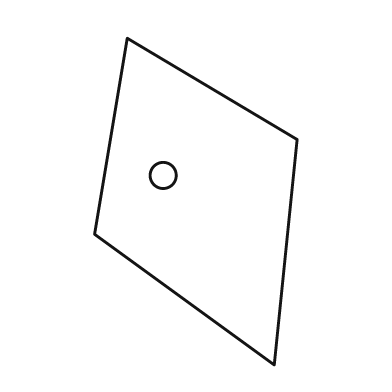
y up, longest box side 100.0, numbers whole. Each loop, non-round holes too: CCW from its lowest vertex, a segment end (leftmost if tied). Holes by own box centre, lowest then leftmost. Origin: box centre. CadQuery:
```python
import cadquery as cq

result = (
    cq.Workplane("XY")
    .moveTo(24.0, -50.0)
    .lineTo(31.0, 19.0)
    .lineTo(-21.0, 50.0)
    .lineTo(-31.0, -10.0)
    .close()
    .moveTo(-10.0, 8.0)
    .circle(4.0)
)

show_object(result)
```